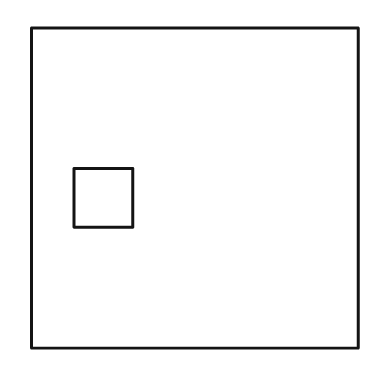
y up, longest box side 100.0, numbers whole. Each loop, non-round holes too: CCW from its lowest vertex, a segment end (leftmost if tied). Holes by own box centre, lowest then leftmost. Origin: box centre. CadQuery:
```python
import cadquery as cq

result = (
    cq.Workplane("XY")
    .moveTo(-50.0, -49.0)
    .lineTo(50.0, -49.0)
    .lineTo(50.0, 49.0)
    .lineTo(-50.0, 49.0)
    .close()
    .moveTo(-37.0, -12.0)
    .lineTo(-19.0, -12.0)
    .lineTo(-19.0, 6.0)
    .lineTo(-37.0, 6.0)
    .close()
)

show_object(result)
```